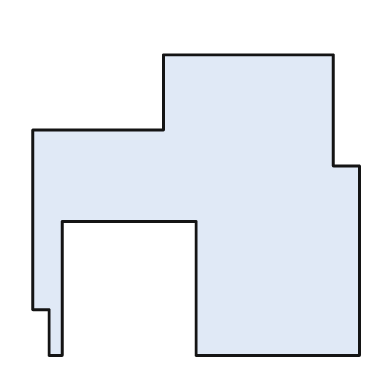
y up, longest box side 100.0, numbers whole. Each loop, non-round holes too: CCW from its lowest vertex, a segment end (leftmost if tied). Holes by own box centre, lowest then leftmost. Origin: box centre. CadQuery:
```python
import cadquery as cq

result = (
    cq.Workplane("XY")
    .moveTo(-45.0, -46.0)
    .lineTo(-41.0, -46.0)
    .lineTo(-41.0, -5.0)
    .lineTo(0.0, -5.0)
    .lineTo(0.0, -46.0)
    .lineTo(50.0, -46.0)
    .lineTo(50.0, 12.0)
    .lineTo(42.0, 12.0)
    .lineTo(42.0, 46.0)
    .lineTo(-10.0, 46.0)
    .lineTo(-10.0, 23.0)
    .lineTo(-50.0, 23.0)
    .lineTo(-50.0, -32.0)
    .lineTo(-45.0, -32.0)
    .close()
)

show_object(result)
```